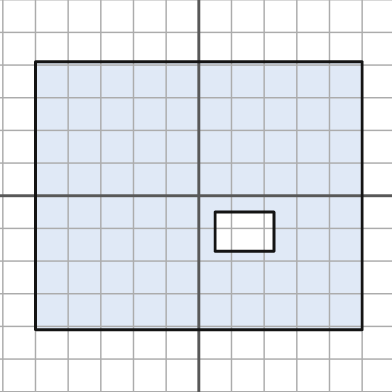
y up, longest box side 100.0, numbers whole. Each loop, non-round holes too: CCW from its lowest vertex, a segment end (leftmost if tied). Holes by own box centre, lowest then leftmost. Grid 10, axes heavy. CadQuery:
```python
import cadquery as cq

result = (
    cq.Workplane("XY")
    .moveTo(-50.0, -41.0)
    .lineTo(50.0, -41.0)
    .lineTo(50.0, 41.0)
    .lineTo(-50.0, 41.0)
    .close()
    .moveTo(5.0, -17.0)
    .lineTo(23.0, -17.0)
    .lineTo(23.0, -5.0)
    .lineTo(5.0, -5.0)
    .close()
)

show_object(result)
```